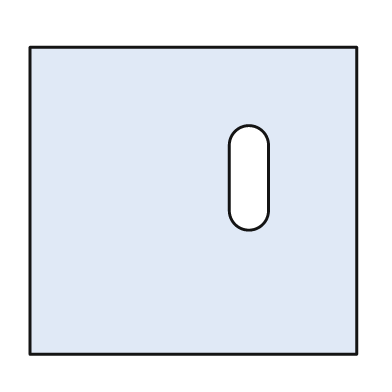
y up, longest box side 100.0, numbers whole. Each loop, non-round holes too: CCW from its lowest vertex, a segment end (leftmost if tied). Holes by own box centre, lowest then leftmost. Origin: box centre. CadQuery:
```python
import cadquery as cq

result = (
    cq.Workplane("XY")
    .moveTo(-50.0, -47.0)
    .lineTo(50.0, -47.0)
    .lineTo(50.0, 47.0)
    .lineTo(-50.0, 47.0)
    .close()
    .moveTo(11.0, -3.0)
    .threePointArc((17.0, -9.0), (23.0, -3.0))
    .lineTo(23.0, 17.0)
    .threePointArc((17.0, 23.0), (11.0, 17.0))
    .close()
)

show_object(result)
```